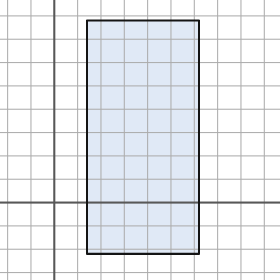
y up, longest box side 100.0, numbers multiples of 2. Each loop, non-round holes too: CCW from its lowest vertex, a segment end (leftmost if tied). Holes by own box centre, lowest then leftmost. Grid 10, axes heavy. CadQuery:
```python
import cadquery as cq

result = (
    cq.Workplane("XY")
    .moveTo(14.0, -22.0)
    .lineTo(62.0, -22.0)
    .lineTo(62.0, 78.0)
    .lineTo(14.0, 78.0)
    .close()
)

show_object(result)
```